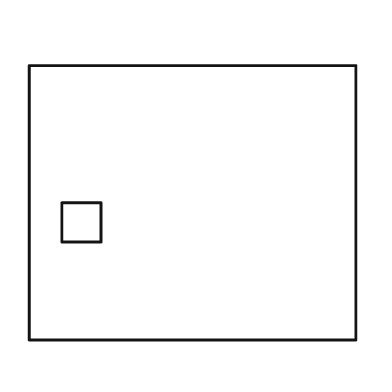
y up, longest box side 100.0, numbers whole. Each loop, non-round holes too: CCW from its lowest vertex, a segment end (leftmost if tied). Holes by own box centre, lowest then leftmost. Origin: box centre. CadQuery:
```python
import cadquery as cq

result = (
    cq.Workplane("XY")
    .moveTo(-50.0, -42.0)
    .lineTo(50.0, -42.0)
    .lineTo(50.0, 42.0)
    .lineTo(-50.0, 42.0)
    .close()
    .moveTo(-40.0, -12.0)
    .lineTo(-28.0, -12.0)
    .lineTo(-28.0, 0.0)
    .lineTo(-40.0, 0.0)
    .close()
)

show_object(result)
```